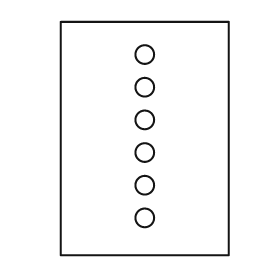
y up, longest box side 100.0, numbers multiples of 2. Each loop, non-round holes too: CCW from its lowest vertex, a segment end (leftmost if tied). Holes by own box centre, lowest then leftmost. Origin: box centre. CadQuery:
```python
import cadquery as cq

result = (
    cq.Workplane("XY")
    .moveTo(-36.0, -50.0)
    .lineTo(36.0, -50.0)
    .lineTo(36.0, 50.0)
    .lineTo(-36.0, 50.0)
    .close()
    .moveTo(0.0, -34.0)
    .circle(4.0)
    .moveTo(0.0, -20.0)
    .circle(4.0)
    .moveTo(0.0, -6.0)
    .circle(4.0)
    .moveTo(0.0, 8.0)
    .circle(4.0)
    .moveTo(0.0, 22.0)
    .circle(4.0)
    .moveTo(0.0, 36.0)
    .circle(4.0)
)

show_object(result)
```